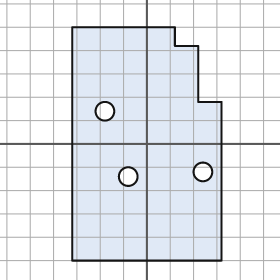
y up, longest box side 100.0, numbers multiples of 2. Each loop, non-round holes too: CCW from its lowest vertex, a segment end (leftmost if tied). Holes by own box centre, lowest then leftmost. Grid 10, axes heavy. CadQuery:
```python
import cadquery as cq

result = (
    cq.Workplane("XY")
    .moveTo(-32.0, -50.0)
    .lineTo(32.0, -50.0)
    .lineTo(32.0, 18.0)
    .lineTo(22.0, 18.0)
    .lineTo(22.0, 42.0)
    .lineTo(12.0, 42.0)
    .lineTo(12.0, 50.0)
    .lineTo(-32.0, 50.0)
    .close()
    .moveTo(-8.0, -14.0)
    .circle(4.0)
    .moveTo(24.0, -12.0)
    .circle(4.0)
    .moveTo(-18.0, 14.0)
    .circle(4.0)
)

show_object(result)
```